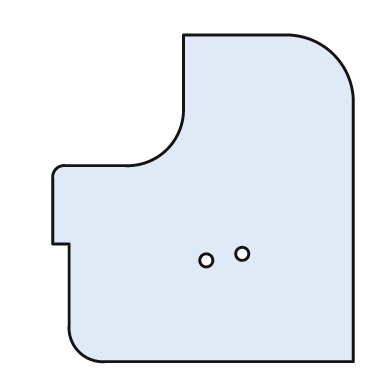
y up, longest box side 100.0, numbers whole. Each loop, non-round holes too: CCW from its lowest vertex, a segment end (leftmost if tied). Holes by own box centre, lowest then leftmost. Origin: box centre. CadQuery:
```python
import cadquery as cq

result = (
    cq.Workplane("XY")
    .moveTo(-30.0, -50.0)
    .lineTo(46.0, -50.0)
    .lineTo(46.0, 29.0)
    .threePointArc((40.0, 44.0), (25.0, 50.0))
    .lineTo(-6.0, 50.0)
    .lineTo(-6.0, 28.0)
    .threePointArc((-11.0, 15.0), (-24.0, 10.0))
    .lineTo(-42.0, 10.0)
    .threePointArc((-45.0, 9.0), (-46.0, 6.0))
    .lineTo(-46.0, -14.0)
    .lineTo(-41.0, -14.0)
    .lineTo(-41.0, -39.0)
    .threePointArc((-38.0, -47.0), (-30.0, -50.0))
    .close()
    .moveTo(1.0, -19.0)
    .circle(2.0)
    .moveTo(12.0, -17.0)
    .circle(2.0)
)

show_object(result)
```